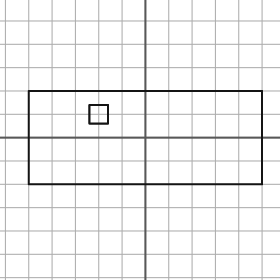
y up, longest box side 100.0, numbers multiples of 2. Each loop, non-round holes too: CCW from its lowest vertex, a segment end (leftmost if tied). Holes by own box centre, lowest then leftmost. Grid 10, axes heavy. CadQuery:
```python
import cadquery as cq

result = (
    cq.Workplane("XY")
    .moveTo(-50.0, -20.0)
    .lineTo(50.0, -20.0)
    .lineTo(50.0, 20.0)
    .lineTo(-50.0, 20.0)
    .close()
    .moveTo(-24.0, 6.0)
    .lineTo(-16.0, 6.0)
    .lineTo(-16.0, 14.0)
    .lineTo(-24.0, 14.0)
    .close()
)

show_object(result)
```